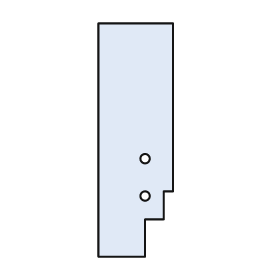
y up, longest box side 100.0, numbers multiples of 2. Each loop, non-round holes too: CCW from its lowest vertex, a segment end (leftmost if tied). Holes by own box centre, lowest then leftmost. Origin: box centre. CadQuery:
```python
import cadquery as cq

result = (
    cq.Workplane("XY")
    .moveTo(-16.0, -50.0)
    .lineTo(4.0, -50.0)
    .lineTo(4.0, -34.0)
    .lineTo(12.0, -34.0)
    .lineTo(12.0, -22.0)
    .lineTo(16.0, -22.0)
    .lineTo(16.0, 50.0)
    .lineTo(-16.0, 50.0)
    .close()
    .moveTo(4.0, -24.0)
    .circle(2.0)
    .moveTo(4.0, -8.0)
    .circle(2.0)
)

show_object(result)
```